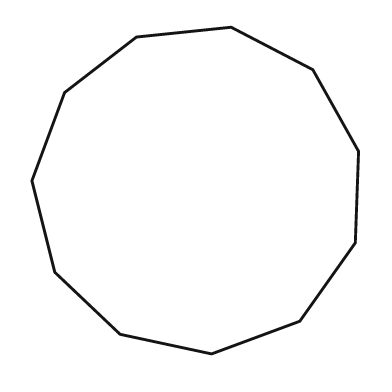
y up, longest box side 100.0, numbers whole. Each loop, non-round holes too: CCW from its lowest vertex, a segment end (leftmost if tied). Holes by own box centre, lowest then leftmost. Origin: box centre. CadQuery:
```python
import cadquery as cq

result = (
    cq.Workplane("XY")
    .moveTo(5.0, -50.0)
    .lineTo(32.0, -40.0)
    .lineTo(49.0, -16.0)
    .lineTo(50.0, 12.0)
    .lineTo(36.0, 37.0)
    .lineTo(11.0, 50.0)
    .lineTo(-18.0, 47.0)
    .lineTo(-40.0, 30.0)
    .lineTo(-50.0, 3.0)
    .lineTo(-43.0, -25.0)
    .lineTo(-23.0, -44.0)
    .close()
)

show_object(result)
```